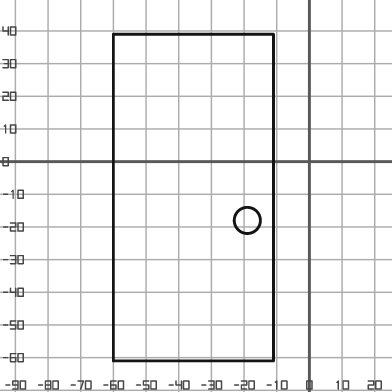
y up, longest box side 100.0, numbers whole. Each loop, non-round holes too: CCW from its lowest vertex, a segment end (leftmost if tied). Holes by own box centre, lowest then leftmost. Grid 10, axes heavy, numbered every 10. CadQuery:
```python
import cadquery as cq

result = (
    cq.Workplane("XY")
    .moveTo(-60.0, -61.0)
    .lineTo(-11.0, -61.0)
    .lineTo(-11.0, 39.0)
    .lineTo(-60.0, 39.0)
    .close()
    .moveTo(-19.0, -18.0)
    .circle(4.0)
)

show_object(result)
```